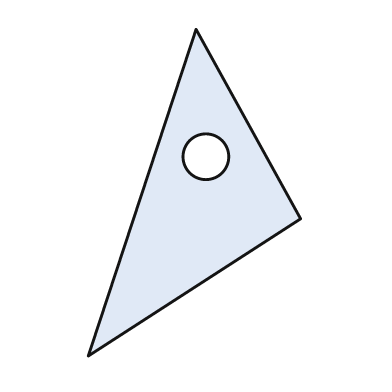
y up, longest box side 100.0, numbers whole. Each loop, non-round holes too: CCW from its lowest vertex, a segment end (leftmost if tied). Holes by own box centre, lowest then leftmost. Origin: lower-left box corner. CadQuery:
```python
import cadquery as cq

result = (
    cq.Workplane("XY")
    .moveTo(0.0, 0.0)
    .lineTo(65.0, 42.0)
    .lineTo(33.0, 100.0)
    .close()
    .moveTo(36.0, 61.0)
    .circle(7.0)
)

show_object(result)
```